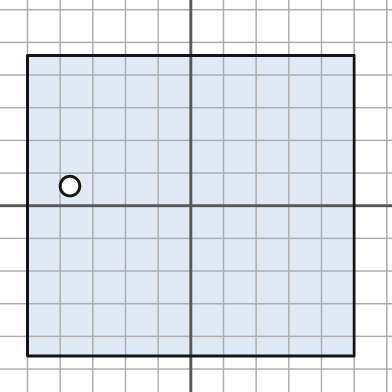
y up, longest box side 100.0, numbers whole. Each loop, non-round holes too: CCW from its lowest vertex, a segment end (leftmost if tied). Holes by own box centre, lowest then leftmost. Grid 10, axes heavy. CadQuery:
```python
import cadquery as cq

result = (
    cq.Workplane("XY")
    .moveTo(-50.0, -46.0)
    .lineTo(50.0, -46.0)
    .lineTo(50.0, 46.0)
    .lineTo(-50.0, 46.0)
    .close()
    .moveTo(-37.0, 6.0)
    .circle(3.0)
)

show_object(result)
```